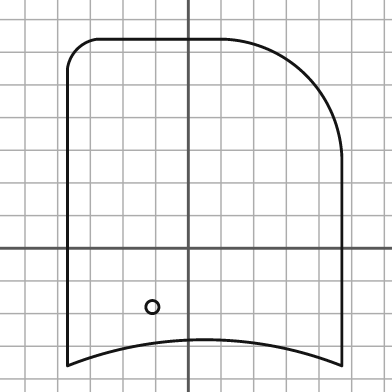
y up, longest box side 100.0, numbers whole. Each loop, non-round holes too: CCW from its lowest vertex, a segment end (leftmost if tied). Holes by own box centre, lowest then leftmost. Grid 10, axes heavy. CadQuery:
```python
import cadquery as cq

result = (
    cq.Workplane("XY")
    .moveTo(-37.0, -36.0)
    .threePointArc((5.0, -28.0), (47.0, -36.0))
    .lineTo(47.0, 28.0)
    .threePointArc((36.0, 53.0), (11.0, 64.0))
    .lineTo(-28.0, 64.0)
    .threePointArc((-34.0, 61.0), (-37.0, 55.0))
    .close()
    .moveTo(-11.0, -18.0)
    .circle(2.0)
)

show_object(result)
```